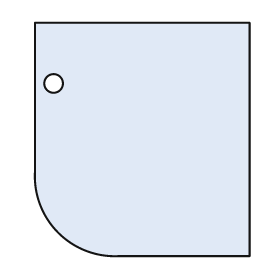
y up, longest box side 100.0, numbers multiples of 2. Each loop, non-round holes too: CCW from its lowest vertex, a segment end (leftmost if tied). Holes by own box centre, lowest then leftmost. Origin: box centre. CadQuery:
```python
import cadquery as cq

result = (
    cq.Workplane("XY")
    .moveTo(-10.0, -50.0)
    .lineTo(46.0, -50.0)
    .lineTo(46.0, 50.0)
    .lineTo(-46.0, 50.0)
    .lineTo(-46.0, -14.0)
    .threePointArc((-36.0, -40.0), (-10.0, -50.0))
    .close()
    .moveTo(-38.0, 24.0)
    .circle(4.0)
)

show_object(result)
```